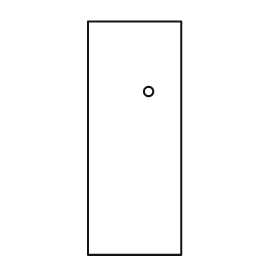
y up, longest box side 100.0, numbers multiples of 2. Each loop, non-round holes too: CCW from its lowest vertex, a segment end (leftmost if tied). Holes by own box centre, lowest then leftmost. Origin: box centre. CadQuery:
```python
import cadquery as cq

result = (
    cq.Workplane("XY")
    .moveTo(-20.0, -50.0)
    .lineTo(20.0, -50.0)
    .lineTo(20.0, 50.0)
    .lineTo(-20.0, 50.0)
    .close()
    .moveTo(6.0, 20.0)
    .circle(2.0)
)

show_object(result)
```